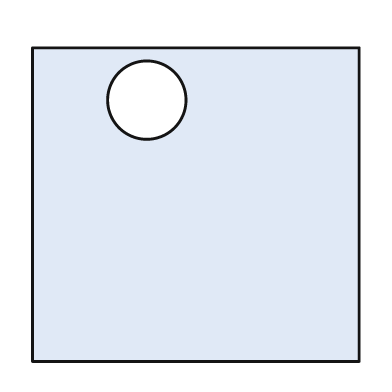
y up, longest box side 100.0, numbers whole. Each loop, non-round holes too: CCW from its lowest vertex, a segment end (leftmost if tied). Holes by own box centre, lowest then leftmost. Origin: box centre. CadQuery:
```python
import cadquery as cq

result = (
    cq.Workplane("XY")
    .moveTo(-50.0, -48.0)
    .lineTo(50.0, -48.0)
    .lineTo(50.0, 48.0)
    .lineTo(-50.0, 48.0)
    .close()
    .moveTo(-15.0, 32.0)
    .circle(12.0)
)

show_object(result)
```